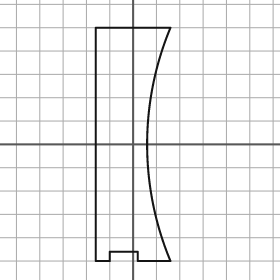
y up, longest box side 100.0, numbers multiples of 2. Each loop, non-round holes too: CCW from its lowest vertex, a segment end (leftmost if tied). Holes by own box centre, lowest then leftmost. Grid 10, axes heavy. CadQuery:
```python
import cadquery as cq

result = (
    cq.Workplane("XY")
    .moveTo(-16.0, -50.0)
    .lineTo(-10.0, -50.0)
    .lineTo(-10.0, -46.0)
    .lineTo(2.0, -46.0)
    .lineTo(2.0, -50.0)
    .lineTo(16.0, -50.0)
    .threePointArc((6.0, 0.0), (16.0, 50.0))
    .lineTo(-16.0, 50.0)
    .close()
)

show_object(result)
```